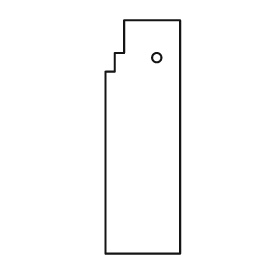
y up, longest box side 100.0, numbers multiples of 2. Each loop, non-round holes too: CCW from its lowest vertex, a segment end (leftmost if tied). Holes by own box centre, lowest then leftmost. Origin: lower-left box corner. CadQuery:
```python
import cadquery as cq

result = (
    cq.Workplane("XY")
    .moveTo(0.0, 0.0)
    .lineTo(32.0, 0.0)
    .lineTo(32.0, 100.0)
    .lineTo(8.0, 100.0)
    .lineTo(8.0, 86.0)
    .lineTo(4.0, 86.0)
    .lineTo(4.0, 78.0)
    .lineTo(0.0, 78.0)
    .close()
    .moveTo(22.0, 84.0)
    .circle(2.0)
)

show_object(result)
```